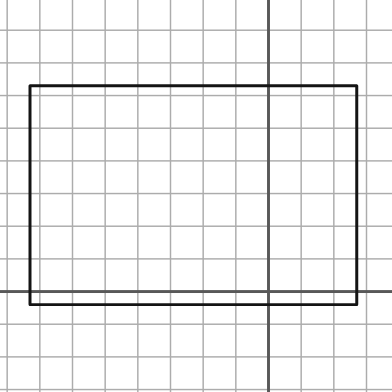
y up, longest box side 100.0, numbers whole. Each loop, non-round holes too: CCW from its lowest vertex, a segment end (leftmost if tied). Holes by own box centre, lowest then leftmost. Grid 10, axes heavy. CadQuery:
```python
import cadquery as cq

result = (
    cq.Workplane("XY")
    .moveTo(-73.0, -4.0)
    .lineTo(27.0, -4.0)
    .lineTo(27.0, 63.0)
    .lineTo(-73.0, 63.0)
    .close()
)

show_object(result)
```